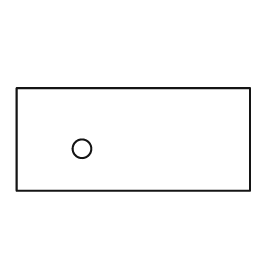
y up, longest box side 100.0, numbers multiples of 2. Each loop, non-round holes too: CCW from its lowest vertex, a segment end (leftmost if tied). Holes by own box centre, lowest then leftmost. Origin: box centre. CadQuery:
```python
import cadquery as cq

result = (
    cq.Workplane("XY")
    .moveTo(-50.0, -22.0)
    .lineTo(50.0, -22.0)
    .lineTo(50.0, 22.0)
    .lineTo(-50.0, 22.0)
    .close()
    .moveTo(-22.0, -4.0)
    .circle(4.0)
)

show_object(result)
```